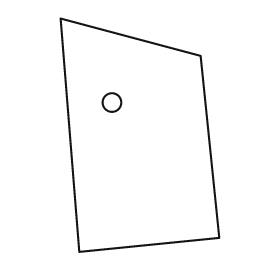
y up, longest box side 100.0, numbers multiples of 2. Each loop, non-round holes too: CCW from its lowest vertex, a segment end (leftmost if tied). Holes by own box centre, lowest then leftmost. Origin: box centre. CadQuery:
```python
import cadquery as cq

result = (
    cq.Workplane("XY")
    .moveTo(-26.0, -50.0)
    .lineTo(34.0, -44.0)
    .lineTo(26.0, 34.0)
    .lineTo(-34.0, 50.0)
    .close()
    .moveTo(-12.0, 14.0)
    .circle(4.0)
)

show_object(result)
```